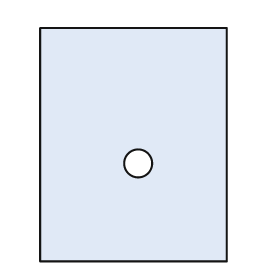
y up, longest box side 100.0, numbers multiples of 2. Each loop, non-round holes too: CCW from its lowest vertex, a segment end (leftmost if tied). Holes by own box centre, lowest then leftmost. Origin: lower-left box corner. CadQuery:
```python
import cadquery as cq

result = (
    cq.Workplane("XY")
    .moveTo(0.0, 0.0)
    .lineTo(80.0, 0.0)
    .lineTo(80.0, 100.0)
    .lineTo(0.0, 100.0)
    .close()
    .moveTo(42.0, 42.0)
    .circle(6.0)
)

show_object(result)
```